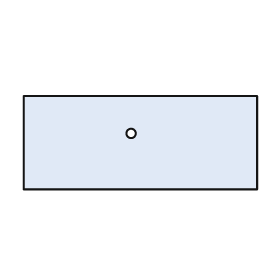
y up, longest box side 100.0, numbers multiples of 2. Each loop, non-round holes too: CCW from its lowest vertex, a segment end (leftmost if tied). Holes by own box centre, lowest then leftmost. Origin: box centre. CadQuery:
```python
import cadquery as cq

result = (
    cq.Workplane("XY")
    .moveTo(-50.0, -20.0)
    .lineTo(50.0, -20.0)
    .lineTo(50.0, 20.0)
    .lineTo(-50.0, 20.0)
    .close()
    .moveTo(-4.0, 4.0)
    .circle(2.0)
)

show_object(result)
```